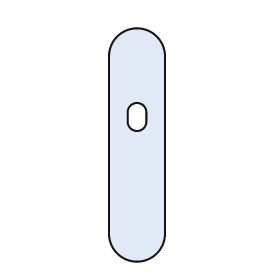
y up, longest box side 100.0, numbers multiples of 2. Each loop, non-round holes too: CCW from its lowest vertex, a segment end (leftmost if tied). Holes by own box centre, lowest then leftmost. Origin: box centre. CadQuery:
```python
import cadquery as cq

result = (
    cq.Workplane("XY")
    .moveTo(-12.0, -38.0)
    .threePointArc((0.0, -50.0), (12.0, -38.0))
    .lineTo(12.0, 38.0)
    .threePointArc((0.0, 50.0), (-12.0, 38.0))
    .close()
    .moveTo(-4.0, 10.0)
    .threePointArc((0.0, 6.0), (4.0, 10.0))
    .lineTo(4.0, 14.0)
    .threePointArc((0.0, 18.0), (-4.0, 14.0))
    .close()
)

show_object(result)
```